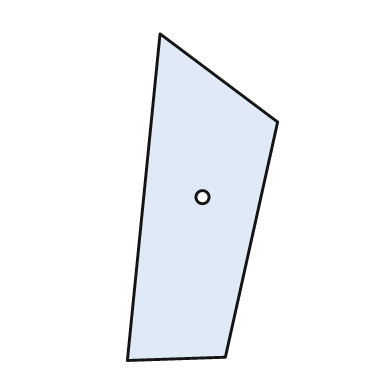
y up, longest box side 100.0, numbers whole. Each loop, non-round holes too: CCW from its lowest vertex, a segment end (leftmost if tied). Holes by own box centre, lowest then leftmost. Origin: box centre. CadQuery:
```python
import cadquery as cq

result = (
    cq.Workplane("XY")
    .moveTo(-23.0, -50.0)
    .lineTo(7.0, -49.0)
    .lineTo(23.0, 23.0)
    .lineTo(-13.0, 50.0)
    .close()
    .moveTo(0.0, 0.0)
    .circle(2.0)
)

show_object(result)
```